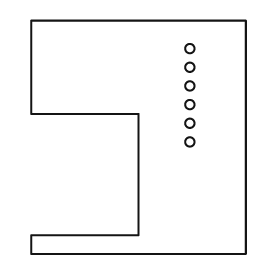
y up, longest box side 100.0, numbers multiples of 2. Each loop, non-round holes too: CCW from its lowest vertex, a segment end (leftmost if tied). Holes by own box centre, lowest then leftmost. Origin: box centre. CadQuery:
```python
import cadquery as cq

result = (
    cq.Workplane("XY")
    .moveTo(-46.0, -50.0)
    .lineTo(46.0, -50.0)
    .lineTo(46.0, 50.0)
    .lineTo(-46.0, 50.0)
    .lineTo(-46.0, 10.0)
    .lineTo(0.0, 10.0)
    .lineTo(0.0, -42.0)
    .lineTo(-46.0, -42.0)
    .close()
    .moveTo(22.0, -2.0)
    .circle(2.0)
    .moveTo(22.0, 6.0)
    .circle(2.0)
    .moveTo(22.0, 14.0)
    .circle(2.0)
    .moveTo(22.0, 22.0)
    .circle(2.0)
    .moveTo(22.0, 30.0)
    .circle(2.0)
    .moveTo(22.0, 38.0)
    .circle(2.0)
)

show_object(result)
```